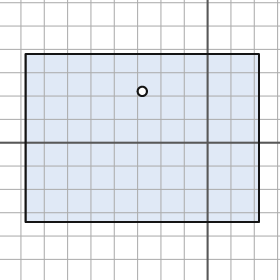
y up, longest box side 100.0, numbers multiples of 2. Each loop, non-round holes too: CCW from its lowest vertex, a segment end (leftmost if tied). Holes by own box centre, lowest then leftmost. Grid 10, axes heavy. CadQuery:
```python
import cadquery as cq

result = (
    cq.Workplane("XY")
    .moveTo(-78.0, -34.0)
    .lineTo(22.0, -34.0)
    .lineTo(22.0, 38.0)
    .lineTo(-78.0, 38.0)
    .close()
    .moveTo(-28.0, 22.0)
    .circle(2.0)
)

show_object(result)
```